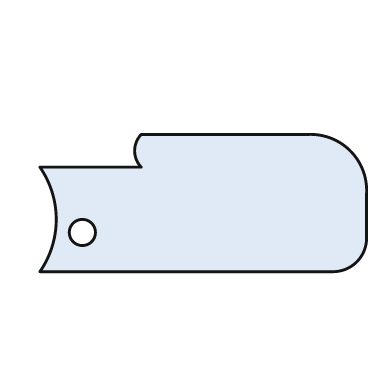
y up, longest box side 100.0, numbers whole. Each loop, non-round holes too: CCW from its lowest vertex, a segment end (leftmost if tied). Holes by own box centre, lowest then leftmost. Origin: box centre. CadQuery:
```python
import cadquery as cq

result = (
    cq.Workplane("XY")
    .moveTo(-50.0, -21.0)
    .lineTo(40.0, -21.0)
    .threePointArc((47.0, -18.0), (50.0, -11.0))
    .lineTo(50.0, 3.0)
    .threePointArc((45.0, 16.0), (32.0, 21.0))
    .lineTo(-19.0, 21.0)
    .threePointArc((-21.0, 16.0), (-19.0, 11.0))
    .lineTo(-50.0, 11.0)
    .threePointArc((-45.0, -5.0), (-50.0, -21.0))
    .close()
    .moveTo(-37.0, -9.0)
    .circle(4.0)
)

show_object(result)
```